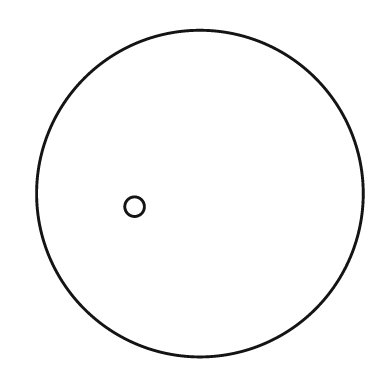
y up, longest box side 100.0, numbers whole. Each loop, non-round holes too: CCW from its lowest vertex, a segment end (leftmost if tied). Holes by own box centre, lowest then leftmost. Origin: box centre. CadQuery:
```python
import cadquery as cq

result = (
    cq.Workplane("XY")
    .moveTo(0.0, 0.0)
    .circle(50.0)
    .moveTo(-20.0, -4.0)
    .circle(3.0)
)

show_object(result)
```